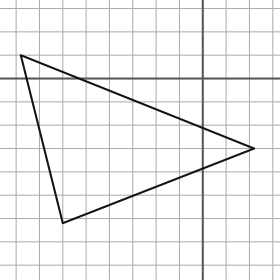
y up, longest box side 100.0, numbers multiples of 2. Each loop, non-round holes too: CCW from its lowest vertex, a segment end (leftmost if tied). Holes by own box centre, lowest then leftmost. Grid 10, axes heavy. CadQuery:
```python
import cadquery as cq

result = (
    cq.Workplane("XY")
    .moveTo(-60.0, -62.0)
    .lineTo(22.0, -30.0)
    .lineTo(-78.0, 10.0)
    .close()
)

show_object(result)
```